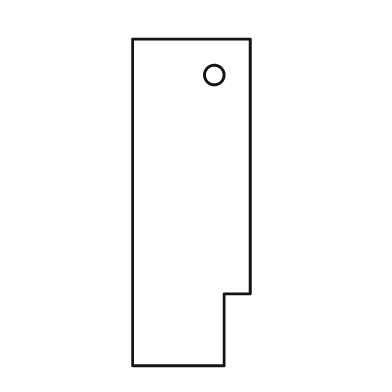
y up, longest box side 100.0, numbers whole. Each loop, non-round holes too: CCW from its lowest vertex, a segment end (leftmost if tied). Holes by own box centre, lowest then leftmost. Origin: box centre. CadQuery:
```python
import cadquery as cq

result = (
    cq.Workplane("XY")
    .moveTo(-18.0, -50.0)
    .lineTo(10.0, -50.0)
    .lineTo(10.0, -28.0)
    .lineTo(18.0, -28.0)
    .lineTo(18.0, 50.0)
    .lineTo(-18.0, 50.0)
    .close()
    .moveTo(7.0, 39.0)
    .circle(3.0)
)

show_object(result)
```